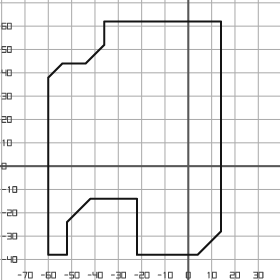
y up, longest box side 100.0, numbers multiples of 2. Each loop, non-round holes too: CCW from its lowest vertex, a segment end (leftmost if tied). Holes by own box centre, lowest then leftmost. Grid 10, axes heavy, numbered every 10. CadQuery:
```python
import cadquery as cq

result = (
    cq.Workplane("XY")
    .moveTo(-60.0, -38.0)
    .lineTo(-52.0, -38.0)
    .lineTo(-52.0, -24.0)
    .lineTo(-42.0, -14.0)
    .lineTo(-22.0, -14.0)
    .lineTo(-22.0, -38.0)
    .lineTo(4.0, -38.0)
    .lineTo(14.0, -28.0)
    .lineTo(14.0, 62.0)
    .lineTo(-36.0, 62.0)
    .lineTo(-36.0, 52.0)
    .lineTo(-44.0, 44.0)
    .lineTo(-54.0, 44.0)
    .lineTo(-60.0, 38.0)
    .close()
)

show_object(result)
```